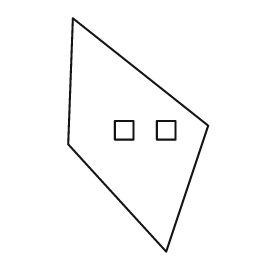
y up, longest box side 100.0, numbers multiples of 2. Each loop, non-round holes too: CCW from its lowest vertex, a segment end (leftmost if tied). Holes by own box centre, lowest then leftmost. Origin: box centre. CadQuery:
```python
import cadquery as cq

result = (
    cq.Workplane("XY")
    .moveTo(12.0, -50.0)
    .lineTo(30.0, 4.0)
    .lineTo(-28.0, 50.0)
    .lineTo(-30.0, -4.0)
    .close()
    .moveTo(-10.0, -2.0)
    .lineTo(-2.0, -2.0)
    .lineTo(-2.0, 6.0)
    .lineTo(-10.0, 6.0)
    .close()
    .moveTo(8.0, -2.0)
    .lineTo(16.0, -2.0)
    .lineTo(16.0, 6.0)
    .lineTo(8.0, 6.0)
    .close()
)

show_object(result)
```